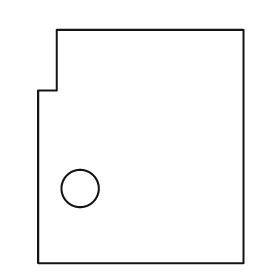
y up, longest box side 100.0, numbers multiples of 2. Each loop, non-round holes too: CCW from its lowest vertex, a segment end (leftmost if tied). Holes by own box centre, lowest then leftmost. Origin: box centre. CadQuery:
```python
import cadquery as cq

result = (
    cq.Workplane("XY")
    .moveTo(-44.0, -50.0)
    .lineTo(44.0, -50.0)
    .lineTo(44.0, 50.0)
    .lineTo(-36.0, 50.0)
    .lineTo(-36.0, 24.0)
    .lineTo(-44.0, 24.0)
    .close()
    .moveTo(-26.0, -18.0)
    .circle(8.0)
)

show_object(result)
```